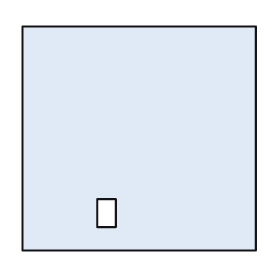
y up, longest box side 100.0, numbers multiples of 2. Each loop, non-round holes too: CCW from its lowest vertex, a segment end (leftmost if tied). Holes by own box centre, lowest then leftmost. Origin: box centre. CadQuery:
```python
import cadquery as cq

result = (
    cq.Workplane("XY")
    .moveTo(-50.0, -48.0)
    .lineTo(50.0, -48.0)
    .lineTo(50.0, 48.0)
    .lineTo(-50.0, 48.0)
    .close()
    .moveTo(-18.0, -38.0)
    .lineTo(-10.0, -38.0)
    .lineTo(-10.0, -26.0)
    .lineTo(-18.0, -26.0)
    .close()
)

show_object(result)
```